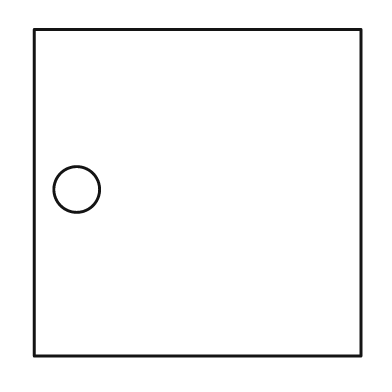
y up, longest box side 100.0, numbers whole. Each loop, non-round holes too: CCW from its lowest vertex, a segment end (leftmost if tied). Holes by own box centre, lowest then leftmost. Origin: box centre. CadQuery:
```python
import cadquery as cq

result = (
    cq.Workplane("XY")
    .moveTo(-50.0, -50.0)
    .lineTo(50.0, -50.0)
    .lineTo(50.0, 50.0)
    .lineTo(-50.0, 50.0)
    .close()
    .moveTo(-37.0, 1.0)
    .circle(7.0)
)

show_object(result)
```